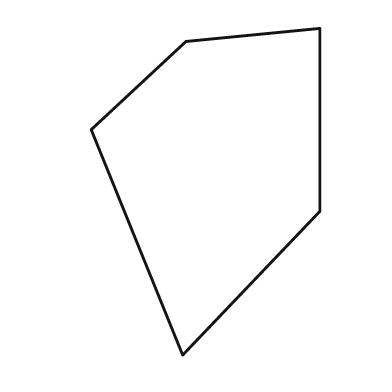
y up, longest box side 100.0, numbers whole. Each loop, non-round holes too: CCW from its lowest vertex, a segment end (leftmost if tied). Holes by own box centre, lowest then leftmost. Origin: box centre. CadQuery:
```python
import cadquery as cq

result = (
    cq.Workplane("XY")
    .moveTo(-7.0, -50.0)
    .lineTo(35.0, -6.0)
    .lineTo(35.0, 50.0)
    .lineTo(-6.0, 46.0)
    .lineTo(-35.0, 19.0)
    .close()
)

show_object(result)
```